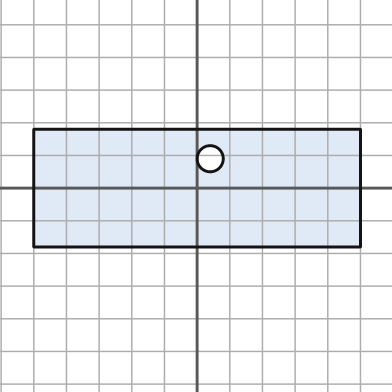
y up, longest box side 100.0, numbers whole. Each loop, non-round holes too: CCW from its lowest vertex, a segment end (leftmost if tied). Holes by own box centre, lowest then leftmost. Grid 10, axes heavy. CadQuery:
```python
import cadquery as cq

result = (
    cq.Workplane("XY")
    .moveTo(-50.0, -18.0)
    .lineTo(50.0, -18.0)
    .lineTo(50.0, 18.0)
    .lineTo(-50.0, 18.0)
    .close()
    .moveTo(4.0, 9.0)
    .circle(4.0)
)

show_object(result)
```